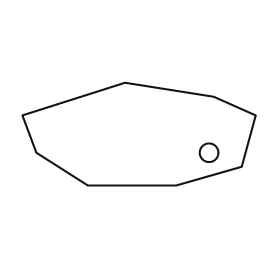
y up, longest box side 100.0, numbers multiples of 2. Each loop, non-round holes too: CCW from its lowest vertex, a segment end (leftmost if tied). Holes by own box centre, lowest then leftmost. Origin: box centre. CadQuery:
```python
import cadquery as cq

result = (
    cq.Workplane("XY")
    .moveTo(-22.0, -22.0)
    .lineTo(16.0, -22.0)
    .lineTo(44.0, -14.0)
    .lineTo(50.0, 8.0)
    .lineTo(32.0, 16.0)
    .lineTo(-6.0, 22.0)
    .lineTo(-50.0, 8.0)
    .lineTo(-44.0, -8.0)
    .close()
    .moveTo(30.0, -8.0)
    .circle(4.0)
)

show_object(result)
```